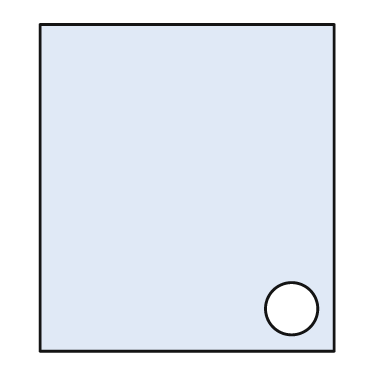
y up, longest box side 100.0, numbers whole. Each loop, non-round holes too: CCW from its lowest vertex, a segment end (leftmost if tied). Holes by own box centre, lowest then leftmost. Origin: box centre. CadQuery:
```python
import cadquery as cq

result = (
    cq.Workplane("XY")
    .moveTo(-45.0, -50.0)
    .lineTo(45.0, -50.0)
    .lineTo(45.0, 50.0)
    .lineTo(-45.0, 50.0)
    .close()
    .moveTo(32.0, -37.0)
    .circle(8.0)
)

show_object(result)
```